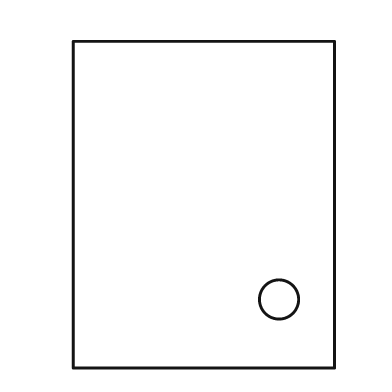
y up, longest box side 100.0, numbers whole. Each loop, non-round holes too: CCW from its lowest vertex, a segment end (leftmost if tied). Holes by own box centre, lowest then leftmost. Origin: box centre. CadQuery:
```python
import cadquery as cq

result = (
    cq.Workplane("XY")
    .moveTo(-40.0, -50.0)
    .lineTo(40.0, -50.0)
    .lineTo(40.0, 50.0)
    .lineTo(-40.0, 50.0)
    .close()
    .moveTo(23.0, -29.0)
    .circle(6.0)
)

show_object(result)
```